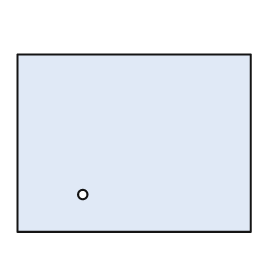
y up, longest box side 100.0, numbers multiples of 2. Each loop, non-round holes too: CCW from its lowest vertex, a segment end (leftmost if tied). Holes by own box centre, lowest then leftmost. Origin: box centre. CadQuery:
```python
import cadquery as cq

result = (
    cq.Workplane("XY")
    .moveTo(-50.0, -38.0)
    .lineTo(50.0, -38.0)
    .lineTo(50.0, 38.0)
    .lineTo(-50.0, 38.0)
    .close()
    .moveTo(-22.0, -22.0)
    .circle(2.0)
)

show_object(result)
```